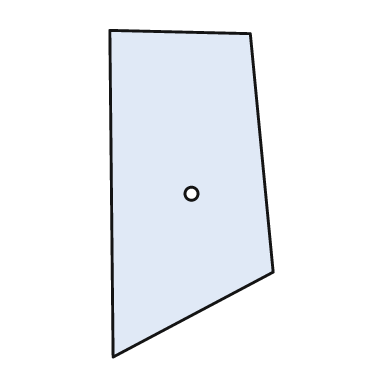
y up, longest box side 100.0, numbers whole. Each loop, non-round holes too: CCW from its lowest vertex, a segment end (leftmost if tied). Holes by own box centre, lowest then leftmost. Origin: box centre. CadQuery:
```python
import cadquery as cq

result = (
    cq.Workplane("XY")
    .moveTo(-24.0, -50.0)
    .lineTo(25.0, -24.0)
    .lineTo(18.0, 49.0)
    .lineTo(-25.0, 50.0)
    .close()
    .moveTo(0.0, 0.0)
    .circle(2.0)
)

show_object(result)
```